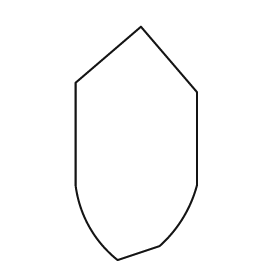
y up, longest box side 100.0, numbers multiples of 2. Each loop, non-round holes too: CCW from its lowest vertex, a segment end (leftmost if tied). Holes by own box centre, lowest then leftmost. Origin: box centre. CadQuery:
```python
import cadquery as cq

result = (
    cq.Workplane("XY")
    .moveTo(-8.0, -50.0)
    .lineTo(10.0, -44.0)
    .threePointArc((20.0, -32.0), (26.0, -18.0))
    .lineTo(26.0, 22.0)
    .lineTo(2.0, 50.0)
    .lineTo(-26.0, 26.0)
    .lineTo(-26.0, -18.0)
    .threePointArc((-20.0, -36.0), (-8.0, -50.0))
    .close()
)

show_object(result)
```